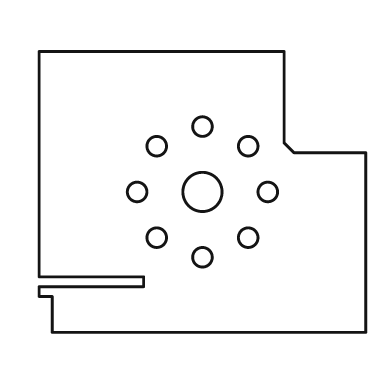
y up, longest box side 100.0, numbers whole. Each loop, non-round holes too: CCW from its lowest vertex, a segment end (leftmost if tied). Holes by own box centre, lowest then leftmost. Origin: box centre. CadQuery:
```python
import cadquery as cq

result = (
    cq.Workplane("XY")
    .moveTo(-46.0, -43.0)
    .lineTo(50.0, -43.0)
    .lineTo(50.0, 12.0)
    .lineTo(28.0, 12.0)
    .lineTo(25.0, 15.0)
    .lineTo(25.0, 43.0)
    .lineTo(-50.0, 43.0)
    .lineTo(-50.0, -26.0)
    .lineTo(-18.0, -26.0)
    .lineTo(-18.0, -29.0)
    .lineTo(-50.0, -29.0)
    .lineTo(-50.0, -32.0)
    .lineTo(-46.0, -32.0)
    .close()
    .moveTo(0.0, -20.0)
    .circle(3.0)
    .moveTo(-14.0, -14.0)
    .circle(3.0)
    .moveTo(14.0, -14.0)
    .circle(3.0)
    .moveTo(-20.0, 0.0)
    .circle(3.0)
    .moveTo(0.0, 0.0)
    .circle(6.0)
    .moveTo(20.0, 0.0)
    .circle(3.0)
    .moveTo(-14.0, 14.0)
    .circle(3.0)
    .moveTo(14.0, 14.0)
    .circle(3.0)
    .moveTo(0.0, 20.0)
    .circle(3.0)
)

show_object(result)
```